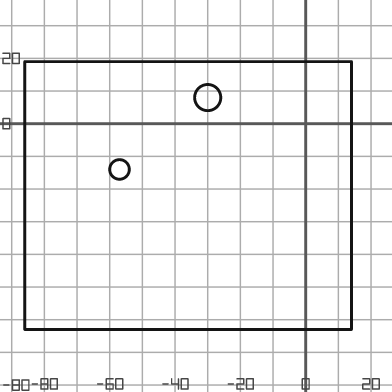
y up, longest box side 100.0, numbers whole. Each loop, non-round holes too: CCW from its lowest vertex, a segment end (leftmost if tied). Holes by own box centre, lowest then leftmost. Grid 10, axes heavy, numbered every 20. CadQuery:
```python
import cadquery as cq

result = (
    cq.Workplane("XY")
    .moveTo(-86.0, -63.0)
    .lineTo(14.0, -63.0)
    .lineTo(14.0, 19.0)
    .lineTo(-86.0, 19.0)
    .close()
    .moveTo(-57.0, -14.0)
    .circle(3.0)
    .moveTo(-30.0, 8.0)
    .circle(4.0)
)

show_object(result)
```